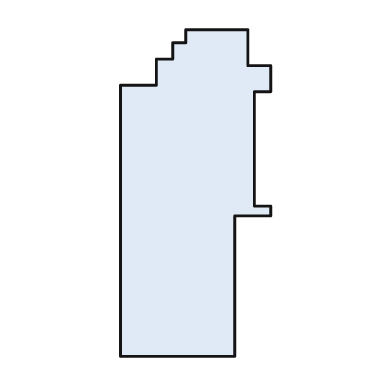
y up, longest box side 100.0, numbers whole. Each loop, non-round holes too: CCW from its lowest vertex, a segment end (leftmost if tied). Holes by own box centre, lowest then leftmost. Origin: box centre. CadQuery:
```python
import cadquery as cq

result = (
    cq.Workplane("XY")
    .moveTo(-23.0, -50.0)
    .lineTo(12.0, -50.0)
    .lineTo(12.0, -7.0)
    .lineTo(23.0, -7.0)
    .lineTo(23.0, -4.0)
    .lineTo(18.0, -4.0)
    .lineTo(18.0, 31.0)
    .lineTo(23.0, 31.0)
    .lineTo(23.0, 39.0)
    .lineTo(16.0, 39.0)
    .lineTo(16.0, 50.0)
    .lineTo(-3.0, 50.0)
    .lineTo(-3.0, 46.0)
    .lineTo(-7.0, 46.0)
    .lineTo(-7.0, 41.0)
    .lineTo(-12.0, 41.0)
    .lineTo(-12.0, 33.0)
    .lineTo(-23.0, 33.0)
    .close()
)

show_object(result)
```